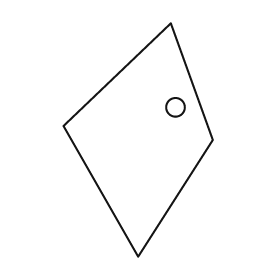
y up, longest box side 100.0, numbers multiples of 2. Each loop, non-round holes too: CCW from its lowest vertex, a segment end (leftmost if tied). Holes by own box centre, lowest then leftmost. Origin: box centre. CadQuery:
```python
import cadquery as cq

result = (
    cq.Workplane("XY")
    .moveTo(0.0, -50.0)
    .lineTo(32.0, 0.0)
    .lineTo(14.0, 50.0)
    .lineTo(-32.0, 6.0)
    .close()
    .moveTo(16.0, 14.0)
    .circle(4.0)
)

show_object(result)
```